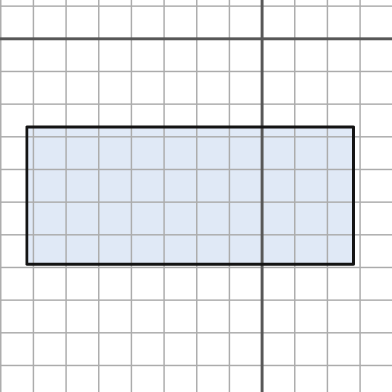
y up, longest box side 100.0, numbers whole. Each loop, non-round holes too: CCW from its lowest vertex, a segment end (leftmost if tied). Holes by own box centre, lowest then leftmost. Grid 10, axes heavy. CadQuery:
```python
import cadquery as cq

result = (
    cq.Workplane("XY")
    .moveTo(-72.0, -69.0)
    .lineTo(28.0, -69.0)
    .lineTo(28.0, -27.0)
    .lineTo(-72.0, -27.0)
    .close()
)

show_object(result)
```